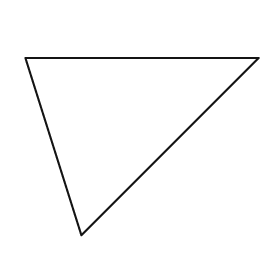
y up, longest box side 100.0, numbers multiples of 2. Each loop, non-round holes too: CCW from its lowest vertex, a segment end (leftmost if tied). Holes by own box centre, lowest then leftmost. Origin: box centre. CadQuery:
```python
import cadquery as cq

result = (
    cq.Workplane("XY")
    .moveTo(-26.0, -38.0)
    .lineTo(50.0, 38.0)
    .lineTo(-50.0, 38.0)
    .close()
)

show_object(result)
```